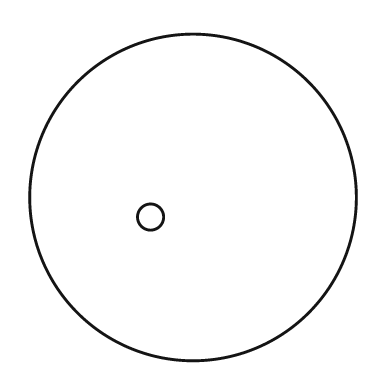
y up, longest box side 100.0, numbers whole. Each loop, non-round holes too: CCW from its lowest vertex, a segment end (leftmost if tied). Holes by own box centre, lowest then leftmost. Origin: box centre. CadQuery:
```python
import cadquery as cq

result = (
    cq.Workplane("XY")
    .moveTo(0.0, 0.0)
    .circle(50.0)
    .moveTo(-13.0, -6.0)
    .circle(4.0)
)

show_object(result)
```